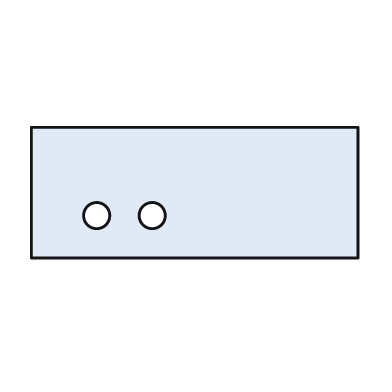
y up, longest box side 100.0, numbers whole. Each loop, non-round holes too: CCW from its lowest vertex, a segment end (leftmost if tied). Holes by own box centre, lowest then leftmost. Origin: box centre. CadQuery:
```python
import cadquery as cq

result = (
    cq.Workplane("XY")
    .moveTo(-50.0, -20.0)
    .lineTo(50.0, -20.0)
    .lineTo(50.0, 20.0)
    .lineTo(-50.0, 20.0)
    .close()
    .moveTo(-30.0, -7.0)
    .circle(4.0)
    .moveTo(-13.0, -7.0)
    .circle(4.0)
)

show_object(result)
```